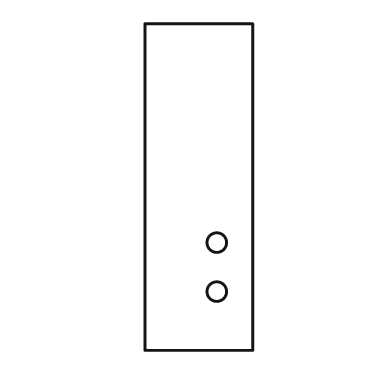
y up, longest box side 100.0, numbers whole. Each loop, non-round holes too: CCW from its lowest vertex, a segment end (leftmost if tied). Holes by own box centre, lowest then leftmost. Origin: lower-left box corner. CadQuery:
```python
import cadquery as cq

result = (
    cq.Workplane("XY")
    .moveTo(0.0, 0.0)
    .lineTo(33.0, 0.0)
    .lineTo(33.0, 100.0)
    .lineTo(0.0, 100.0)
    .close()
    .moveTo(22.0, 18.0)
    .circle(3.0)
    .moveTo(22.0, 33.0)
    .circle(3.0)
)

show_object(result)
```